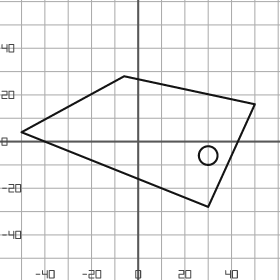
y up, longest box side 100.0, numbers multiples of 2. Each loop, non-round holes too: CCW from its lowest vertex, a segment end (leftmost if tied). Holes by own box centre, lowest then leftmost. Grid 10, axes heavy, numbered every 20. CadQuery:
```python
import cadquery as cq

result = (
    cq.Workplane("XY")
    .moveTo(30.0, -28.0)
    .lineTo(50.0, 16.0)
    .lineTo(-6.0, 28.0)
    .lineTo(-50.0, 4.0)
    .close()
    .moveTo(30.0, -6.0)
    .circle(4.0)
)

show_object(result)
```